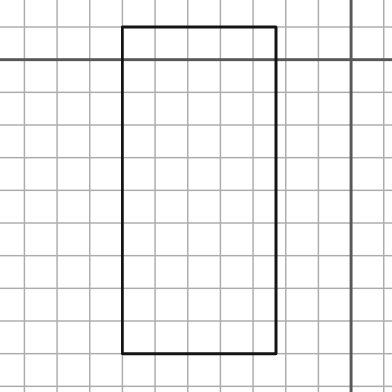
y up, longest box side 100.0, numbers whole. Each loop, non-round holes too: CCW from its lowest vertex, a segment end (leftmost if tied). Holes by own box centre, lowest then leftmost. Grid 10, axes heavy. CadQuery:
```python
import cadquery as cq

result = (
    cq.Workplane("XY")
    .moveTo(-70.0, -90.0)
    .lineTo(-23.0, -90.0)
    .lineTo(-23.0, 10.0)
    .lineTo(-70.0, 10.0)
    .close()
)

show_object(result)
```